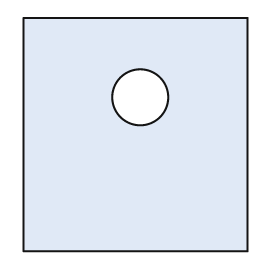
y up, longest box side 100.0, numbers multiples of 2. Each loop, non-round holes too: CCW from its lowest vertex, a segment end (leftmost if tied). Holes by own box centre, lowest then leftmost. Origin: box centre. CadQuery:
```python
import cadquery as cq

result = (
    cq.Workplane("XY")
    .moveTo(-48.0, -50.0)
    .lineTo(48.0, -50.0)
    .lineTo(48.0, 50.0)
    .lineTo(-48.0, 50.0)
    .close()
    .moveTo(2.0, 16.0)
    .circle(12.0)
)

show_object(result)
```